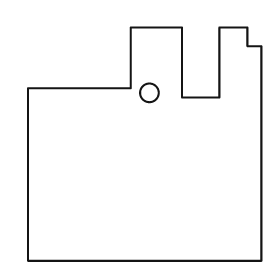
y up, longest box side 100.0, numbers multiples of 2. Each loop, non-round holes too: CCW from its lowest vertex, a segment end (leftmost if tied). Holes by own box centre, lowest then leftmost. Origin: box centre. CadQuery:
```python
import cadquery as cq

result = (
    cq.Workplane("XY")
    .moveTo(-50.0, -50.0)
    .lineTo(50.0, -50.0)
    .lineTo(50.0, 42.0)
    .lineTo(44.0, 42.0)
    .lineTo(44.0, 50.0)
    .lineTo(32.0, 50.0)
    .lineTo(32.0, 20.0)
    .lineTo(16.0, 20.0)
    .lineTo(16.0, 50.0)
    .lineTo(-6.0, 50.0)
    .lineTo(-6.0, 24.0)
    .lineTo(-50.0, 24.0)
    .close()
    .moveTo(2.0, 22.0)
    .circle(4.0)
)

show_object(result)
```